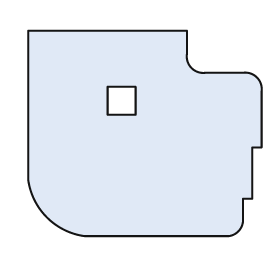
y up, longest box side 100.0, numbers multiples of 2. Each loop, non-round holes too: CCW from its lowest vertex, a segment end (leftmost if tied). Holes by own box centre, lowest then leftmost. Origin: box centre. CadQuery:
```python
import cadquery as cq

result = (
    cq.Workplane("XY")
    .moveTo(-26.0, -44.0)
    .lineTo(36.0, -44.0)
    .threePointArc((40.0, -42.0), (42.0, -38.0))
    .lineTo(42.0, -28.0)
    .lineTo(46.0, -28.0)
    .lineTo(46.0, -6.0)
    .lineTo(50.0, -6.0)
    .lineTo(50.0, 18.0)
    .threePointArc((48.0, 24.0), (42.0, 26.0))
    .lineTo(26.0, 26.0)
    .threePointArc((20.0, 28.0), (18.0, 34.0))
    .lineTo(18.0, 44.0)
    .lineTo(-50.0, 44.0)
    .lineTo(-50.0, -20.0)
    .threePointArc((-42.0, -36.0), (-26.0, -44.0))
    .close()
    .moveTo(-16.0, 8.0)
    .lineTo(-4.0, 8.0)
    .lineTo(-4.0, 20.0)
    .lineTo(-16.0, 20.0)
    .close()
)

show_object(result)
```